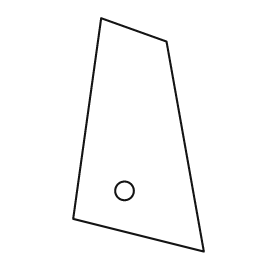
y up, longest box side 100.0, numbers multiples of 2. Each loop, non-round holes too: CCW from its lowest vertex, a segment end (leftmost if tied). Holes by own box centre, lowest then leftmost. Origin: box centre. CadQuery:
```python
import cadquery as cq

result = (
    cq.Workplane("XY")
    .moveTo(28.0, -50.0)
    .lineTo(12.0, 40.0)
    .lineTo(-16.0, 50.0)
    .lineTo(-28.0, -36.0)
    .close()
    .moveTo(-6.0, -24.0)
    .circle(4.0)
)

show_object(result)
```